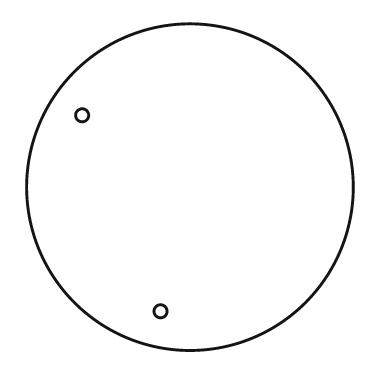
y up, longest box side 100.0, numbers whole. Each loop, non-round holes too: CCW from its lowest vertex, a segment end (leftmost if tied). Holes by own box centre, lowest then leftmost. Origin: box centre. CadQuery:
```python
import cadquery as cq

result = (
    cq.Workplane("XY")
    .moveTo(0.0, 0.0)
    .circle(50.0)
    .moveTo(-9.0, -38.0)
    .circle(2.0)
    .moveTo(-33.0, 22.0)
    .circle(2.0)
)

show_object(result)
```